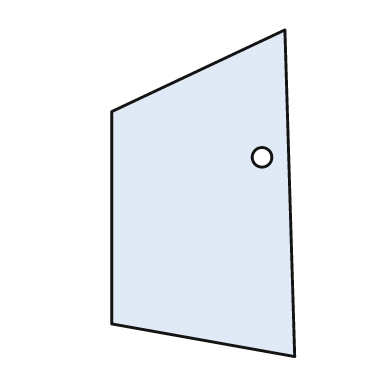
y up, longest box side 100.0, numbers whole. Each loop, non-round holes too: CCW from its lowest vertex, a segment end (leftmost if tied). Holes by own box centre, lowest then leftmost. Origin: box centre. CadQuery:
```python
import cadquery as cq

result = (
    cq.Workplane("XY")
    .moveTo(28.0, -50.0)
    .lineTo(25.0, 50.0)
    .lineTo(-28.0, 25.0)
    .lineTo(-28.0, -40.0)
    .close()
    .moveTo(18.0, 11.0)
    .circle(3.0)
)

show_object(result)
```